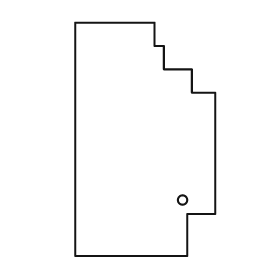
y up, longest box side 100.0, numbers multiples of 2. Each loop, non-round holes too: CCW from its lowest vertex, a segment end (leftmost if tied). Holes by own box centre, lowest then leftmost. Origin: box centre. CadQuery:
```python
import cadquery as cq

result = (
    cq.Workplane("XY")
    .moveTo(-30.0, -50.0)
    .lineTo(18.0, -50.0)
    .lineTo(18.0, -32.0)
    .lineTo(30.0, -32.0)
    .lineTo(30.0, 20.0)
    .lineTo(20.0, 20.0)
    .lineTo(20.0, 30.0)
    .lineTo(8.0, 30.0)
    .lineTo(8.0, 40.0)
    .lineTo(4.0, 40.0)
    .lineTo(4.0, 50.0)
    .lineTo(-30.0, 50.0)
    .close()
    .moveTo(16.0, -26.0)
    .circle(2.0)
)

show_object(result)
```